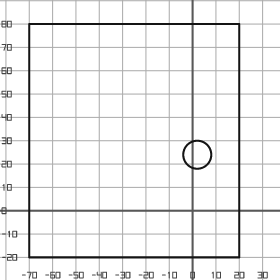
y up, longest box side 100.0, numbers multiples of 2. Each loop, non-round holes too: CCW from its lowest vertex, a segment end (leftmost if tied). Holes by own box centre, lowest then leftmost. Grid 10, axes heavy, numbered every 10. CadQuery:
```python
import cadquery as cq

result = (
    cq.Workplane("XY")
    .moveTo(-70.0, -20.0)
    .lineTo(20.0, -20.0)
    .lineTo(20.0, 80.0)
    .lineTo(-70.0, 80.0)
    .close()
    .moveTo(2.0, 24.0)
    .circle(6.0)
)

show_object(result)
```